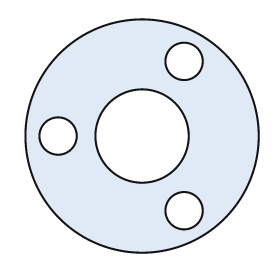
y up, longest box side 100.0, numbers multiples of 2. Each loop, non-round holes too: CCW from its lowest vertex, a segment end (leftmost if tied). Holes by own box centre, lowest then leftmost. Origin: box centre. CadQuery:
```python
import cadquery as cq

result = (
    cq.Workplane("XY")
    .moveTo(0.0, 0.0)
    .circle(50.0)
    .moveTo(18.0, -32.0)
    .circle(8.0)
    .moveTo(-36.0, 0.0)
    .circle(8.0)
    .moveTo(0.0, 0.0)
    .circle(20.0)
    .moveTo(18.0, 32.0)
    .circle(8.0)
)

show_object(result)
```